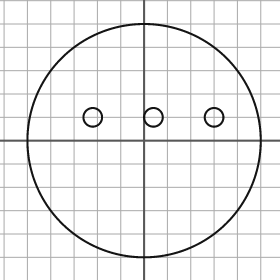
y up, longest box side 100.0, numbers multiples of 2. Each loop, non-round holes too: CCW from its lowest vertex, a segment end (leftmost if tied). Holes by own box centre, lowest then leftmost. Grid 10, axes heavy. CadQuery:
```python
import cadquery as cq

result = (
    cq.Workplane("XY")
    .moveTo(0.0, 0.0)
    .circle(50.0)
    .moveTo(-22.0, 10.0)
    .circle(4.0)
    .moveTo(4.0, 10.0)
    .circle(4.0)
    .moveTo(30.0, 10.0)
    .circle(4.0)
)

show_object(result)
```